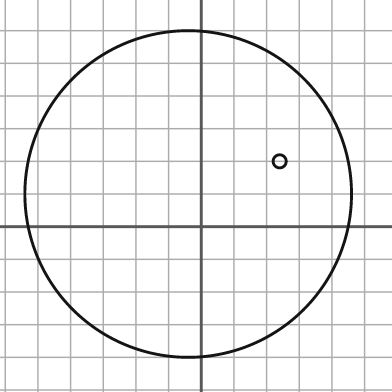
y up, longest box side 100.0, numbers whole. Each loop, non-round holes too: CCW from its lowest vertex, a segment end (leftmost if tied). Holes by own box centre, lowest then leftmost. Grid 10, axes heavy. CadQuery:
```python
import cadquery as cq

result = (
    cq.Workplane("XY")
    .moveTo(-4.0, 10.0)
    .circle(50.0)
    .moveTo(24.0, 20.0)
    .circle(2.0)
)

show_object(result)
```